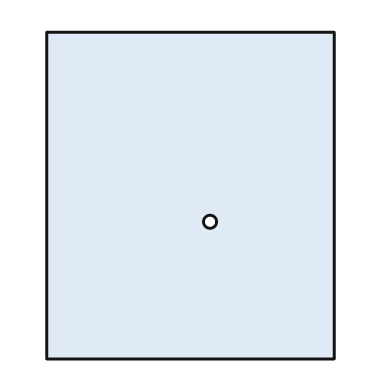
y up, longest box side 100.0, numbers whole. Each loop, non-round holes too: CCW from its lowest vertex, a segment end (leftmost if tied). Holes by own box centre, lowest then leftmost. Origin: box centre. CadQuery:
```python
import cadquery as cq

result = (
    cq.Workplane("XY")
    .moveTo(-44.0, -50.0)
    .lineTo(44.0, -50.0)
    .lineTo(44.0, 50.0)
    .lineTo(-44.0, 50.0)
    .close()
    .moveTo(6.0, -8.0)
    .circle(2.0)
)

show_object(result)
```